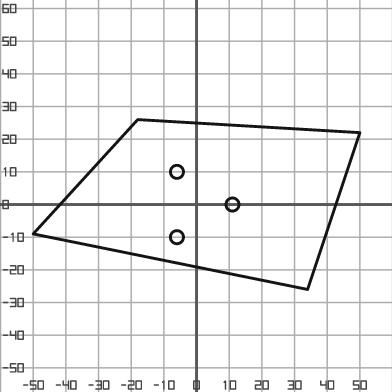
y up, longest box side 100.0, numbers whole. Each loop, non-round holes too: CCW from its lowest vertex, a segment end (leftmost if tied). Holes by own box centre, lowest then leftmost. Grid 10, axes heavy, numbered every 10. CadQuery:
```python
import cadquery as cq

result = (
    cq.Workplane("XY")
    .moveTo(34.0, -26.0)
    .lineTo(50.0, 22.0)
    .lineTo(-18.0, 26.0)
    .lineTo(-50.0, -9.0)
    .close()
    .moveTo(-6.0, -10.0)
    .circle(2.0)
    .moveTo(11.0, 0.0)
    .circle(2.0)
    .moveTo(-6.0, 10.0)
    .circle(2.0)
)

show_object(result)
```